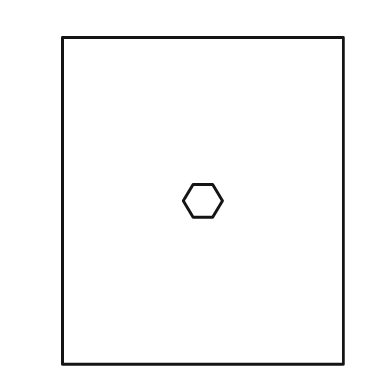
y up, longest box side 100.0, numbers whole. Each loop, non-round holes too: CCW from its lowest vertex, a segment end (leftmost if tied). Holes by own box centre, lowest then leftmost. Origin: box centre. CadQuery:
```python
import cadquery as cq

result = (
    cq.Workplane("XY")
    .moveTo(-43.0, -50.0)
    .lineTo(43.0, -50.0)
    .lineTo(43.0, 50.0)
    .lineTo(-43.0, 50.0)
    .close()
    .moveTo(-3.0, -5.0)
    .lineTo(3.0, -5.0)
    .lineTo(6.0, 0.0)
    .lineTo(3.0, 5.0)
    .lineTo(-3.0, 5.0)
    .lineTo(-6.0, 0.0)
    .close()
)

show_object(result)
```